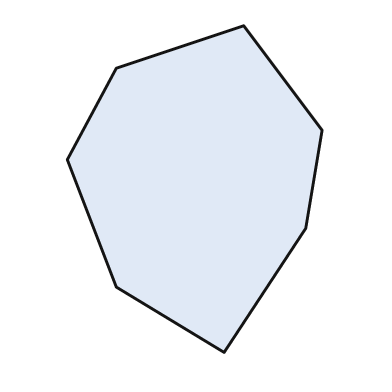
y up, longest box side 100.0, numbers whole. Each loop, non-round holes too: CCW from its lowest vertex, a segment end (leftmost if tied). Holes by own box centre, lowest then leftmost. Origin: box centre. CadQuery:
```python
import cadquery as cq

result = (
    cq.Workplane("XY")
    .moveTo(9.0, -50.0)
    .lineTo(34.0, -12.0)
    .lineTo(39.0, 18.0)
    .lineTo(15.0, 50.0)
    .lineTo(-24.0, 37.0)
    .lineTo(-39.0, 9.0)
    .lineTo(-24.0, -30.0)
    .close()
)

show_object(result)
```